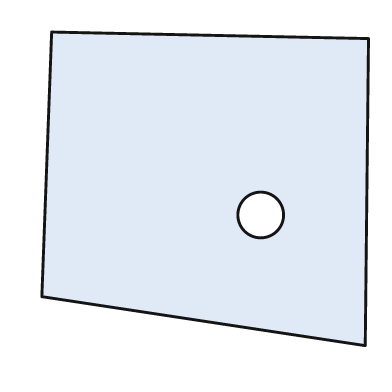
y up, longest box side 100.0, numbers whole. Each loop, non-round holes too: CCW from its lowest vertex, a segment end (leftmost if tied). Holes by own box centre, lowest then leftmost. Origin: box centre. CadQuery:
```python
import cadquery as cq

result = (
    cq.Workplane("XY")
    .moveTo(49.0, -48.0)
    .lineTo(50.0, 46.0)
    .lineTo(-47.0, 48.0)
    .lineTo(-50.0, -33.0)
    .close()
    .moveTo(17.0, -8.0)
    .circle(7.0)
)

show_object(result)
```